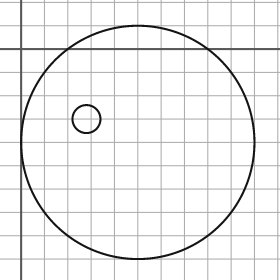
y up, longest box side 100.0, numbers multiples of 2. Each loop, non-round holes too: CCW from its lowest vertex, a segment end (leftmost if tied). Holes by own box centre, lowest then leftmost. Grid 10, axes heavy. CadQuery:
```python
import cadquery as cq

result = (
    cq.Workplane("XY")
    .moveTo(50.0, -40.0)
    .circle(50.0)
    .moveTo(28.0, -30.0)
    .circle(6.0)
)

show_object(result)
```